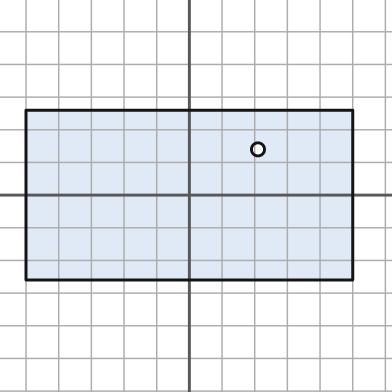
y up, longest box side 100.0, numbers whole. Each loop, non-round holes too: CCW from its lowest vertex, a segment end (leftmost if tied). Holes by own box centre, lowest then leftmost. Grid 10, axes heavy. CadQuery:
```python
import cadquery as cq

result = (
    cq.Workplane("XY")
    .moveTo(-50.0, -26.0)
    .lineTo(50.0, -26.0)
    .lineTo(50.0, 26.0)
    .lineTo(-50.0, 26.0)
    .close()
    .moveTo(21.0, 14.0)
    .circle(2.0)
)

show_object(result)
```